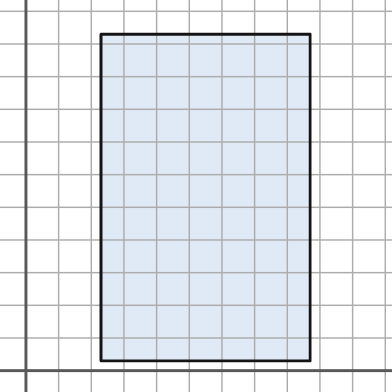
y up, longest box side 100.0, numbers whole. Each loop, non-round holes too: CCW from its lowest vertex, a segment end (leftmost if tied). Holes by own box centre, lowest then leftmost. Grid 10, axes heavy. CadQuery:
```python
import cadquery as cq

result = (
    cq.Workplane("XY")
    .moveTo(23.0, 3.0)
    .lineTo(87.0, 3.0)
    .lineTo(87.0, 103.0)
    .lineTo(23.0, 103.0)
    .close()
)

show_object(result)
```